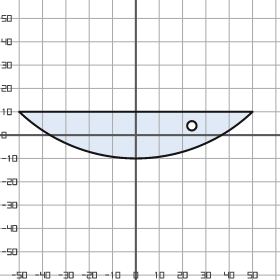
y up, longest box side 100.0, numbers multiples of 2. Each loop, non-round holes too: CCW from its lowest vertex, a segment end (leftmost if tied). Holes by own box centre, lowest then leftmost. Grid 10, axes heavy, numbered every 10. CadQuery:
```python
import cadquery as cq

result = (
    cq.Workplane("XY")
    .moveTo(-50.0, 10.0)
    .threePointArc((0.0, -10.0), (50.0, 10.0))
    .close()
    .moveTo(24.0, 4.0)
    .circle(2.0)
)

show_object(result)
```